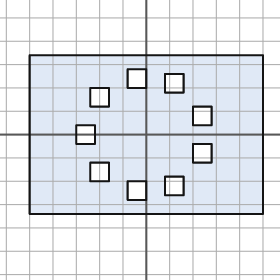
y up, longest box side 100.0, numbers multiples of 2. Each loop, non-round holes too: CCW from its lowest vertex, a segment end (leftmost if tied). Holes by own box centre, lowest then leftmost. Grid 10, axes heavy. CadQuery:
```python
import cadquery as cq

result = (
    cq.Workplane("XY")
    .moveTo(-50.0, -34.0)
    .lineTo(50.0, -34.0)
    .lineTo(50.0, 34.0)
    .lineTo(-50.0, 34.0)
    .close()
    .moveTo(-8.0, -28.0)
    .lineTo(0.0, -28.0)
    .lineTo(0.0, -20.0)
    .lineTo(-8.0, -20.0)
    .close()
    .moveTo(8.0, -26.0)
    .lineTo(16.0, -26.0)
    .lineTo(16.0, -18.0)
    .lineTo(8.0, -18.0)
    .close()
    .moveTo(-24.0, -20.0)
    .lineTo(-16.0, -20.0)
    .lineTo(-16.0, -12.0)
    .lineTo(-24.0, -12.0)
    .close()
    .moveTo(20.0, -12.0)
    .lineTo(28.0, -12.0)
    .lineTo(28.0, -4.0)
    .lineTo(20.0, -4.0)
    .close()
    .moveTo(-30.0, -4.0)
    .lineTo(-22.0, -4.0)
    .lineTo(-22.0, 4.0)
    .lineTo(-30.0, 4.0)
    .close()
    .moveTo(20.0, 4.0)
    .lineTo(28.0, 4.0)
    .lineTo(28.0, 12.0)
    .lineTo(20.0, 12.0)
    .close()
    .moveTo(-24.0, 12.0)
    .lineTo(-16.0, 12.0)
    .lineTo(-16.0, 20.0)
    .lineTo(-24.0, 20.0)
    .close()
    .moveTo(8.0, 18.0)
    .lineTo(16.0, 18.0)
    .lineTo(16.0, 26.0)
    .lineTo(8.0, 26.0)
    .close()
    .moveTo(-8.0, 20.0)
    .lineTo(0.0, 20.0)
    .lineTo(0.0, 28.0)
    .lineTo(-8.0, 28.0)
    .close()
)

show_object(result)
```